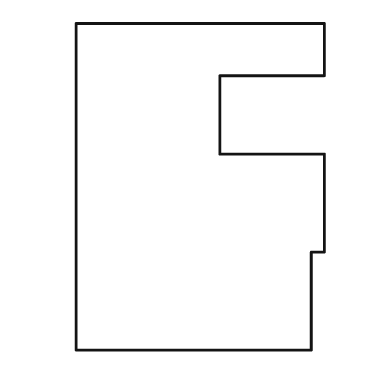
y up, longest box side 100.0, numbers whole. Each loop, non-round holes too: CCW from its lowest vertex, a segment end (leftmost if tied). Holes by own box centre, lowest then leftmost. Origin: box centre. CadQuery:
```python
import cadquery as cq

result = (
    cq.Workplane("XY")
    .moveTo(-38.0, -50.0)
    .lineTo(34.0, -50.0)
    .lineTo(34.0, -20.0)
    .lineTo(38.0, -20.0)
    .lineTo(38.0, 10.0)
    .lineTo(6.0, 10.0)
    .lineTo(6.0, 34.0)
    .lineTo(38.0, 34.0)
    .lineTo(38.0, 50.0)
    .lineTo(-38.0, 50.0)
    .close()
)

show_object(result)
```